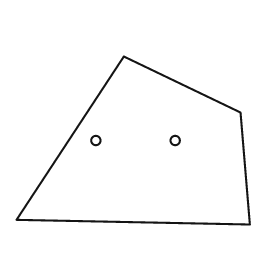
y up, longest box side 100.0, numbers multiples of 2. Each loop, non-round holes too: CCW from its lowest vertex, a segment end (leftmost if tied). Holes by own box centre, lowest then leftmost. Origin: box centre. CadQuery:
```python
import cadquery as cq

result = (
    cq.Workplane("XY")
    .moveTo(50.0, -36.0)
    .lineTo(46.0, 12.0)
    .lineTo(-4.0, 36.0)
    .lineTo(-50.0, -34.0)
    .close()
    .moveTo(-16.0, 0.0)
    .circle(2.0)
    .moveTo(18.0, 0.0)
    .circle(2.0)
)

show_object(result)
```